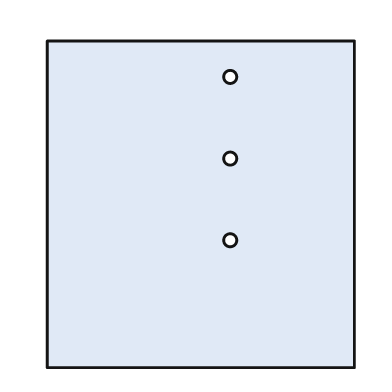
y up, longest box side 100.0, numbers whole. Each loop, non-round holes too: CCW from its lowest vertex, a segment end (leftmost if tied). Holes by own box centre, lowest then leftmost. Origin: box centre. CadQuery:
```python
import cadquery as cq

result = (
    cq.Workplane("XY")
    .moveTo(-47.0, -50.0)
    .lineTo(47.0, -50.0)
    .lineTo(47.0, 50.0)
    .lineTo(-47.0, 50.0)
    .close()
    .moveTo(9.0, -11.0)
    .circle(2.0)
    .moveTo(9.0, 14.0)
    .circle(2.0)
    .moveTo(9.0, 39.0)
    .circle(2.0)
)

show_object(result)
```